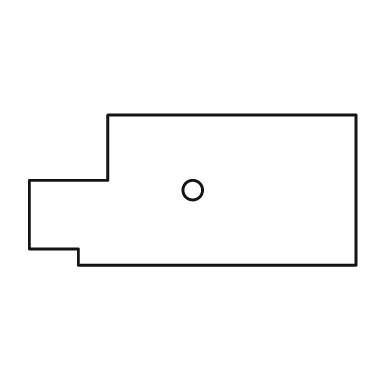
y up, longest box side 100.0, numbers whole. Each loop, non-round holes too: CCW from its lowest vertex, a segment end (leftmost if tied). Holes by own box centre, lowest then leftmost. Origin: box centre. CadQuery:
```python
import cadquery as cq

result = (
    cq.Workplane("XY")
    .moveTo(-35.0, -23.0)
    .lineTo(50.0, -23.0)
    .lineTo(50.0, 23.0)
    .lineTo(-26.0, 23.0)
    .lineTo(-26.0, 3.0)
    .lineTo(-50.0, 3.0)
    .lineTo(-50.0, -18.0)
    .lineTo(-35.0, -18.0)
    .close()
    .moveTo(0.0, 0.0)
    .circle(3.0)
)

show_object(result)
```